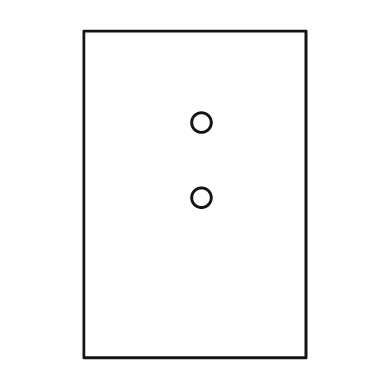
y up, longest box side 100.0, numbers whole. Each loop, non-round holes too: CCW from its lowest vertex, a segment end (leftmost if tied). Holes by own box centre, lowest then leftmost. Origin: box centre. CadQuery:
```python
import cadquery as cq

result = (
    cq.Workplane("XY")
    .moveTo(-34.0, -50.0)
    .lineTo(34.0, -50.0)
    .lineTo(34.0, 50.0)
    .lineTo(-34.0, 50.0)
    .close()
    .moveTo(2.0, -1.0)
    .circle(3.0)
    .moveTo(2.0, 22.0)
    .circle(3.0)
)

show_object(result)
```